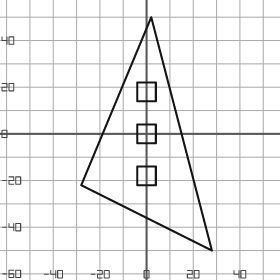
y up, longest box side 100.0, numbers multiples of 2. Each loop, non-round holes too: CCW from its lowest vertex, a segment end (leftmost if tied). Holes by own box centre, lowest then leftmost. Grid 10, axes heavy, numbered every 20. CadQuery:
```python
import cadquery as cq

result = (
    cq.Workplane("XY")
    .moveTo(28.0, -50.0)
    .lineTo(2.0, 50.0)
    .lineTo(-28.0, -22.0)
    .close()
    .moveTo(-4.0, -22.0)
    .lineTo(4.0, -22.0)
    .lineTo(4.0, -14.0)
    .lineTo(-4.0, -14.0)
    .close()
    .moveTo(-4.0, -4.0)
    .lineTo(4.0, -4.0)
    .lineTo(4.0, 4.0)
    .lineTo(-4.0, 4.0)
    .close()
    .moveTo(-4.0, 14.0)
    .lineTo(4.0, 14.0)
    .lineTo(4.0, 22.0)
    .lineTo(-4.0, 22.0)
    .close()
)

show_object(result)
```